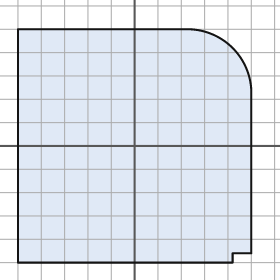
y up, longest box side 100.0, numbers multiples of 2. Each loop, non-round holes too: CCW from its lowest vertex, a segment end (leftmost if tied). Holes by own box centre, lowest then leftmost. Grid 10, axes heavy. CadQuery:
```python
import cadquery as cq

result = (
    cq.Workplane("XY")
    .moveTo(-50.0, -50.0)
    .lineTo(42.0, -50.0)
    .lineTo(42.0, -46.0)
    .lineTo(50.0, -46.0)
    .lineTo(50.0, 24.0)
    .threePointArc((42.0, 42.0), (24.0, 50.0))
    .lineTo(-50.0, 50.0)
    .close()
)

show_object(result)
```